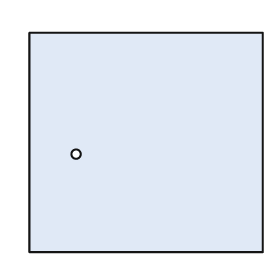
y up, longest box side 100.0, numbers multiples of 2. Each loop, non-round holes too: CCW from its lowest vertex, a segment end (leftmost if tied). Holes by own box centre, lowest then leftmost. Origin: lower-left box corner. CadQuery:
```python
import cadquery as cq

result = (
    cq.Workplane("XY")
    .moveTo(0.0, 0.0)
    .lineTo(100.0, 0.0)
    .lineTo(100.0, 94.0)
    .lineTo(0.0, 94.0)
    .close()
    .moveTo(20.0, 42.0)
    .circle(2.0)
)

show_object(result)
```